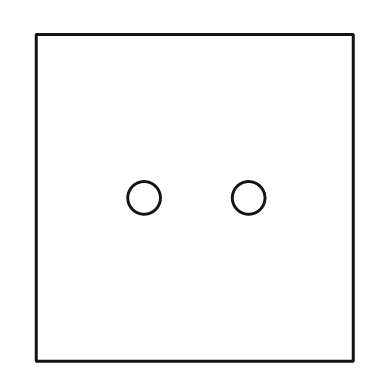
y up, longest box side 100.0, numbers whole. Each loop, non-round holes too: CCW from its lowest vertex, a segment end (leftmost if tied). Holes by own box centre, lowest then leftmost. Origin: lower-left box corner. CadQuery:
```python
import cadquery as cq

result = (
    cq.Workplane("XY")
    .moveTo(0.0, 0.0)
    .lineTo(97.0, 0.0)
    .lineTo(97.0, 100.0)
    .lineTo(0.0, 100.0)
    .close()
    .moveTo(33.0, 50.0)
    .circle(5.0)
    .moveTo(65.0, 50.0)
    .circle(5.0)
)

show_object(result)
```